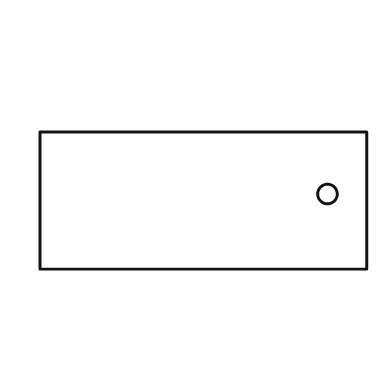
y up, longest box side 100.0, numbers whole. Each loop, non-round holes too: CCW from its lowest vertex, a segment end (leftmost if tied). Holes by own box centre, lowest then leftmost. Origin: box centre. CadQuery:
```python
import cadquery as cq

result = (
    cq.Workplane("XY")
    .moveTo(-50.0, -21.0)
    .lineTo(50.0, -21.0)
    .lineTo(50.0, 21.0)
    .lineTo(-50.0, 21.0)
    .close()
    .moveTo(38.0, 2.0)
    .circle(3.0)
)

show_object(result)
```